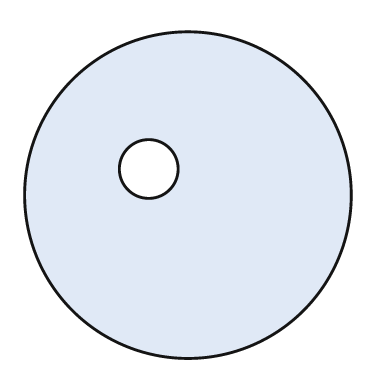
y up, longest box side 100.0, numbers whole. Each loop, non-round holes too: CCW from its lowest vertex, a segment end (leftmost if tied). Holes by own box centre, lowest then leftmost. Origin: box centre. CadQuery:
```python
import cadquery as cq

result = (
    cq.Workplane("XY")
    .moveTo(0.0, 0.0)
    .circle(50.0)
    .moveTo(-12.0, 8.0)
    .circle(9.0)
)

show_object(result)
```